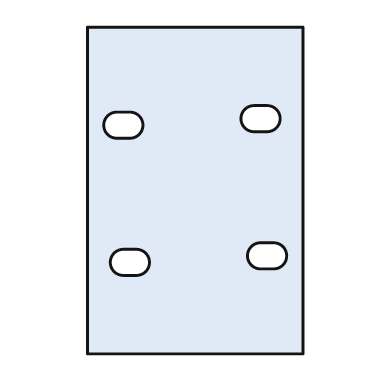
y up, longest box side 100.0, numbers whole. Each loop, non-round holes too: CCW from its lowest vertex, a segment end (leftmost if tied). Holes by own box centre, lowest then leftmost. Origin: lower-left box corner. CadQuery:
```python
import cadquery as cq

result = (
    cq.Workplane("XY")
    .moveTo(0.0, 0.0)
    .lineTo(66.0, 0.0)
    .lineTo(66.0, 100.0)
    .lineTo(0.0, 100.0)
    .close()
    .moveTo(11.0, 24.0)
    .lineTo(15.0, 24.0)
    .threePointArc((19.0, 28.0), (15.0, 32.0))
    .lineTo(11.0, 32.0)
    .threePointArc((7.0, 28.0), (11.0, 24.0))
    .close()
    .moveTo(53.0, 26.0)
    .lineTo(57.0, 26.0)
    .threePointArc((61.0, 30.0), (57.0, 34.0))
    .lineTo(53.0, 34.0)
    .threePointArc((49.0, 30.0), (53.0, 26.0))
    .close()
    .moveTo(9.0, 66.0)
    .lineTo(13.0, 66.0)
    .threePointArc((17.0, 70.0), (13.0, 74.0))
    .lineTo(9.0, 74.0)
    .threePointArc((5.0, 70.0), (9.0, 66.0))
    .close()
    .moveTo(51.0, 68.0)
    .lineTo(55.0, 68.0)
    .threePointArc((59.0, 72.0), (55.0, 76.0))
    .lineTo(51.0, 76.0)
    .threePointArc((47.0, 72.0), (51.0, 68.0))
    .close()
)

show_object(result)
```